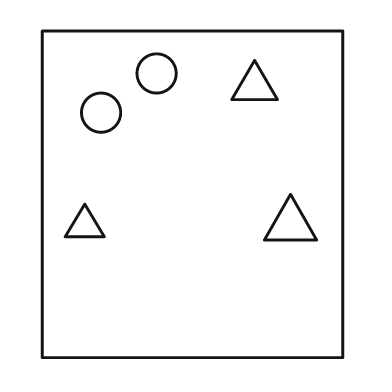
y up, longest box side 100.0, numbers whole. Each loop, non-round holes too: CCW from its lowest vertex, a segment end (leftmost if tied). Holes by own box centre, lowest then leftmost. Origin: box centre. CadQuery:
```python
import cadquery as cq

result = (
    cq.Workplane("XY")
    .moveTo(-46.0, -50.0)
    .lineTo(46.0, -50.0)
    .lineTo(46.0, 50.0)
    .lineTo(-46.0, 50.0)
    .close()
    .moveTo(-39.0, -13.0)
    .lineTo(-27.0, -13.0)
    .lineTo(-33.0, -3.0)
    .close()
    .moveTo(22.0, -14.0)
    .lineTo(38.0, -14.0)
    .lineTo(30.0, 0.0)
    .close()
    .moveTo(-28.0, 25.0)
    .circle(6.0)
    .moveTo(12.0, 29.0)
    .lineTo(26.0, 29.0)
    .lineTo(19.0, 41.0)
    .close()
    .moveTo(-11.0, 37.0)
    .circle(6.0)
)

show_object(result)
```